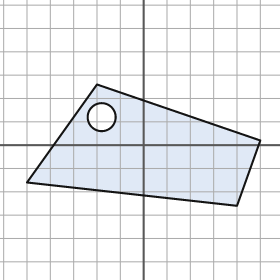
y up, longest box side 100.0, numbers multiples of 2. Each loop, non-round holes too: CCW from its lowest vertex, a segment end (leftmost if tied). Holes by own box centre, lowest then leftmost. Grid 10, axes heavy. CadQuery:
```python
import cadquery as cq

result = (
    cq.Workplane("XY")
    .moveTo(40.0, -26.0)
    .lineTo(50.0, 2.0)
    .lineTo(-20.0, 26.0)
    .lineTo(-50.0, -16.0)
    .close()
    .moveTo(-18.0, 12.0)
    .circle(6.0)
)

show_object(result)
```